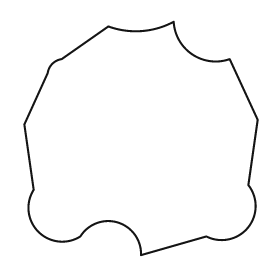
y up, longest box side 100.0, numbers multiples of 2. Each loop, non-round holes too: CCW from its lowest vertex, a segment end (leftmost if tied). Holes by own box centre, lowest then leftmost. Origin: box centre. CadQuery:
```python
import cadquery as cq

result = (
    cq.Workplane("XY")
    .moveTo(0.0, -50.0)
    .lineTo(28.0, -42.0)
    .threePointArc((46.0, -38.0), (46.0, -20.0))
    .lineTo(50.0, 8.0)
    .lineTo(38.0, 34.0)
    .threePointArc((22.0, 36.0), (14.0, 50.0))
    .threePointArc((0.0, 46.0), (-14.0, 48.0))
    .lineTo(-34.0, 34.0)
    .threePointArc((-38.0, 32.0), (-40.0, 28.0))
    .lineTo(-50.0, 6.0)
    .lineTo(-46.0, -22.0)
    .threePointArc((-44.0, -40.0), (-26.0, -42.0))
    .threePointArc((-10.0, -36.0), (0.0, -50.0))
    .close()
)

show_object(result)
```